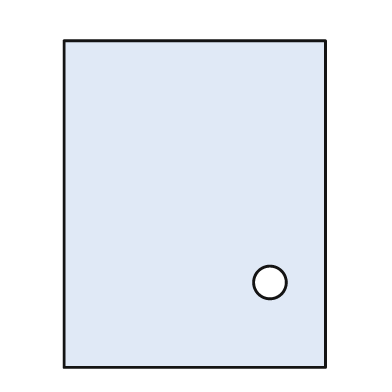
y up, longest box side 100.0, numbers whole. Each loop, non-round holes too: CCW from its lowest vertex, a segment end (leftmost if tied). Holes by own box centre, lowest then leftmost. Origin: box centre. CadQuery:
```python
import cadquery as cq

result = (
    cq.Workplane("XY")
    .moveTo(-40.0, -50.0)
    .lineTo(40.0, -50.0)
    .lineTo(40.0, 50.0)
    .lineTo(-40.0, 50.0)
    .close()
    .moveTo(23.0, -24.0)
    .circle(5.0)
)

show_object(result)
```